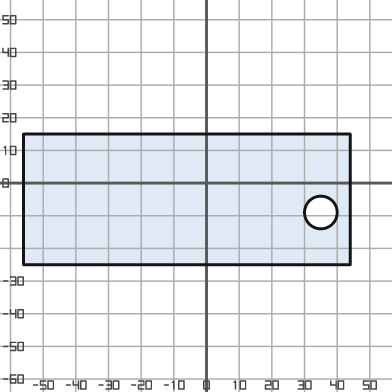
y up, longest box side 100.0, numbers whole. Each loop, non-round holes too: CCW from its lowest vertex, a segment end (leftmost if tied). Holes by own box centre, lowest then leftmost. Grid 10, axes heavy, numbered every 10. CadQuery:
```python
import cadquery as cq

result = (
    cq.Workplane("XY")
    .moveTo(-56.0, -25.0)
    .lineTo(44.0, -25.0)
    .lineTo(44.0, 15.0)
    .lineTo(-56.0, 15.0)
    .close()
    .moveTo(35.0, -9.0)
    .circle(5.0)
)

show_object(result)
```